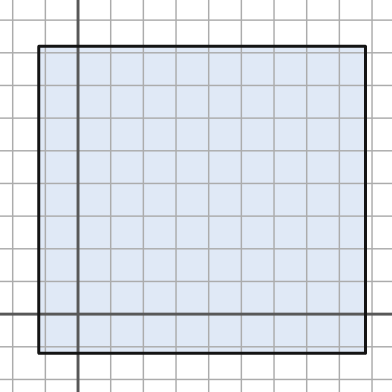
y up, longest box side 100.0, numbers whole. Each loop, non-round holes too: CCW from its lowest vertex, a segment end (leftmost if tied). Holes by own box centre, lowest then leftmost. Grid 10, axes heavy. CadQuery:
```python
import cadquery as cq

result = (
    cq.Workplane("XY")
    .moveTo(-12.0, -12.0)
    .lineTo(88.0, -12.0)
    .lineTo(88.0, 82.0)
    .lineTo(-12.0, 82.0)
    .close()
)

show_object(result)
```